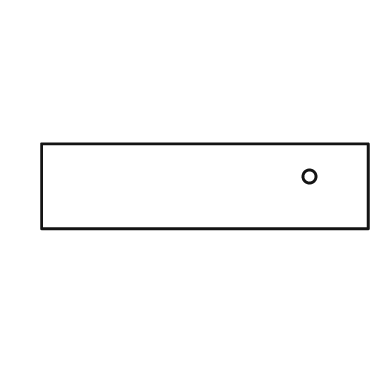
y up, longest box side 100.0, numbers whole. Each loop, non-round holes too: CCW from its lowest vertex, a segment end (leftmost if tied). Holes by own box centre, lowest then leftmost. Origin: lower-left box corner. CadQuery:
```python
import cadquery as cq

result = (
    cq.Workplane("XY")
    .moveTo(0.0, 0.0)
    .lineTo(100.0, 0.0)
    .lineTo(100.0, 26.0)
    .lineTo(0.0, 26.0)
    .close()
    .moveTo(82.0, 16.0)
    .circle(2.0)
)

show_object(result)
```